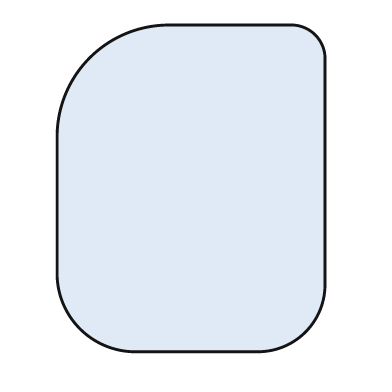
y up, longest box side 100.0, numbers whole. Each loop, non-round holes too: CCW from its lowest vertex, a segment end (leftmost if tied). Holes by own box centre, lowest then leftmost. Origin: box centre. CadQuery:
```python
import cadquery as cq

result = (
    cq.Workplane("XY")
    .moveTo(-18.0, -50.0)
    .lineTo(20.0, -50.0)
    .threePointArc((35.0, -44.0), (41.0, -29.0))
    .lineTo(41.0, 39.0)
    .threePointArc((38.0, 47.0), (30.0, 50.0))
    .lineTo(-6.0, 50.0)
    .threePointArc((-31.0, 40.0), (-41.0, 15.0))
    .lineTo(-41.0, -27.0)
    .threePointArc((-34.0, -43.0), (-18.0, -50.0))
    .close()
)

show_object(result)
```